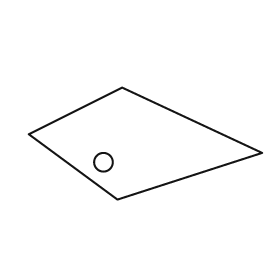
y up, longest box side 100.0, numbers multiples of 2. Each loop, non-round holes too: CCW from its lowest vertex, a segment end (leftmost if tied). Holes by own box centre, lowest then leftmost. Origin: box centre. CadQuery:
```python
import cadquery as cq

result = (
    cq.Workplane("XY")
    .moveTo(-12.0, -24.0)
    .lineTo(50.0, -4.0)
    .lineTo(-10.0, 24.0)
    .lineTo(-50.0, 4.0)
    .close()
    .moveTo(-18.0, -8.0)
    .circle(4.0)
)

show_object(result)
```